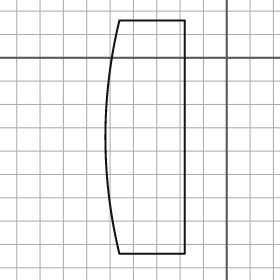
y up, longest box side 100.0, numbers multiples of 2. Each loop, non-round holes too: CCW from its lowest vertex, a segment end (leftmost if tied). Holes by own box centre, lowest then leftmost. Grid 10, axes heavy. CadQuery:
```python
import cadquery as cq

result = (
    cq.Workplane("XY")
    .moveTo(-46.0, -84.0)
    .lineTo(-18.0, -84.0)
    .lineTo(-18.0, 16.0)
    .lineTo(-46.0, 16.0)
    .threePointArc((-52.0, -34.0), (-46.0, -84.0))
    .close()
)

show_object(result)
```